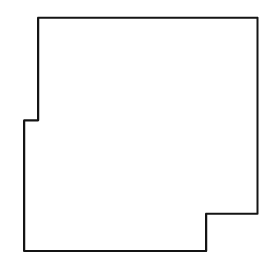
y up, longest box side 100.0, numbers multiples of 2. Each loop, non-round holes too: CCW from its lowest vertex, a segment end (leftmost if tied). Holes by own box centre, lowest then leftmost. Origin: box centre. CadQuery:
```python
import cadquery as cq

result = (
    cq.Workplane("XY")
    .moveTo(-50.0, -50.0)
    .lineTo(28.0, -50.0)
    .lineTo(28.0, -34.0)
    .lineTo(50.0, -34.0)
    .lineTo(50.0, 50.0)
    .lineTo(-44.0, 50.0)
    .lineTo(-44.0, 6.0)
    .lineTo(-50.0, 6.0)
    .close()
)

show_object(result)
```